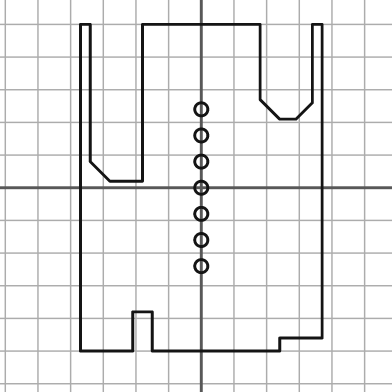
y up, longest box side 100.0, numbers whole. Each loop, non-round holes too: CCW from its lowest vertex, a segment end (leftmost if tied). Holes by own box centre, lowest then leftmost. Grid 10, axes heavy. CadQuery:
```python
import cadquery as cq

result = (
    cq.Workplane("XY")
    .moveTo(-37.0, -50.0)
    .lineTo(-21.0, -50.0)
    .lineTo(-21.0, -38.0)
    .lineTo(-15.0, -38.0)
    .lineTo(-15.0, -50.0)
    .lineTo(24.0, -50.0)
    .lineTo(24.0, -46.0)
    .lineTo(37.0, -46.0)
    .lineTo(37.0, 50.0)
    .lineTo(34.0, 50.0)
    .lineTo(34.0, 26.0)
    .lineTo(29.0, 21.0)
    .lineTo(24.0, 21.0)
    .lineTo(18.0, 27.0)
    .lineTo(18.0, 50.0)
    .lineTo(-18.0, 50.0)
    .lineTo(-18.0, 2.0)
    .lineTo(-28.0, 2.0)
    .lineTo(-34.0, 8.0)
    .lineTo(-34.0, 50.0)
    .lineTo(-37.0, 50.0)
    .close()
    .moveTo(0.0, -24.0)
    .circle(2.0)
    .moveTo(0.0, -16.0)
    .circle(2.0)
    .moveTo(0.0, -8.0)
    .circle(2.0)
    .moveTo(0.0, 0.0)
    .circle(2.0)
    .moveTo(0.0, 8.0)
    .circle(2.0)
    .moveTo(0.0, 16.0)
    .circle(2.0)
    .moveTo(0.0, 24.0)
    .circle(2.0)
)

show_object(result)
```